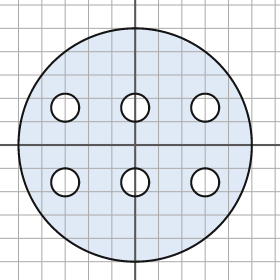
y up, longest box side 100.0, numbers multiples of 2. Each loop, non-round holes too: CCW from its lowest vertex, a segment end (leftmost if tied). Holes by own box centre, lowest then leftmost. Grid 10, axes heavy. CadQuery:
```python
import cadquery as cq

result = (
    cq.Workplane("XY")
    .moveTo(0.0, 0.0)
    .circle(50.0)
    .moveTo(-30.0, -16.0)
    .circle(6.0)
    .moveTo(0.0, -16.0)
    .circle(6.0)
    .moveTo(30.0, -16.0)
    .circle(6.0)
    .moveTo(-30.0, 16.0)
    .circle(6.0)
    .moveTo(0.0, 16.0)
    .circle(6.0)
    .moveTo(30.0, 16.0)
    .circle(6.0)
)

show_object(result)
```